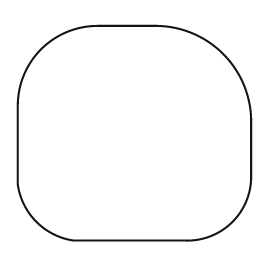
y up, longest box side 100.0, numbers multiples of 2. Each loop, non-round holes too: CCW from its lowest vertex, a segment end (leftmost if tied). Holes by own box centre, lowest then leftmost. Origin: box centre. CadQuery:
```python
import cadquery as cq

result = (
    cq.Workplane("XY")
    .moveTo(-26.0, -46.0)
    .lineTo(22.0, -46.0)
    .threePointArc((42.0, -38.0), (50.0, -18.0))
    .lineTo(50.0, 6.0)
    .threePointArc((38.0, 34.0), (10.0, 46.0))
    .lineTo(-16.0, 46.0)
    .threePointArc((-40.0, 36.0), (-50.0, 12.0))
    .lineTo(-50.0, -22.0)
    .threePointArc((-42.0, -38.0), (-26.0, -46.0))
    .close()
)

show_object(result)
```